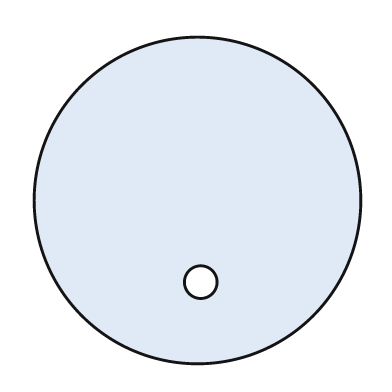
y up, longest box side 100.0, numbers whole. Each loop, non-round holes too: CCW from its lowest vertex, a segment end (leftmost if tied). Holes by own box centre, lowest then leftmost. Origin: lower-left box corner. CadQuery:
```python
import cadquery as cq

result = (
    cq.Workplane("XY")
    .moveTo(50.0, 50.0)
    .circle(50.0)
    .moveTo(51.0, 25.0)
    .circle(5.0)
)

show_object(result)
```